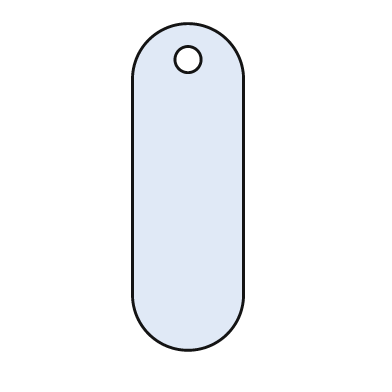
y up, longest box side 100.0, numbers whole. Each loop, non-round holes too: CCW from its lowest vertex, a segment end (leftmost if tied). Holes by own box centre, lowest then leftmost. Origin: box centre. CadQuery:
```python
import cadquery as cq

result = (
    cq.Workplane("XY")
    .moveTo(-17.0, -33.0)
    .threePointArc((0.0, -50.0), (17.0, -33.0))
    .lineTo(17.0, 33.0)
    .threePointArc((0.0, 50.0), (-17.0, 33.0))
    .close()
    .moveTo(0.0, 39.0)
    .circle(4.0)
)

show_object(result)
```